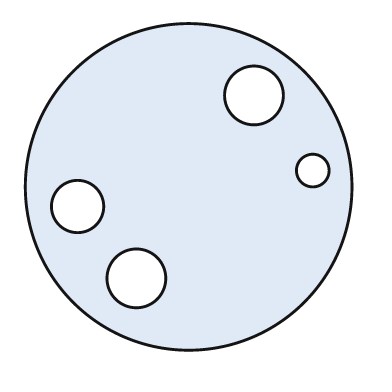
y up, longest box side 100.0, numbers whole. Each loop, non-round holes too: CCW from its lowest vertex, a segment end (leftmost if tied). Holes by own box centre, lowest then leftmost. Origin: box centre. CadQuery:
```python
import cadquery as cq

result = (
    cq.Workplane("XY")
    .moveTo(0.0, 0.0)
    .circle(50.0)
    .moveTo(-16.0, -28.0)
    .circle(9.0)
    .moveTo(-34.0, -6.0)
    .circle(8.0)
    .moveTo(38.0, 5.0)
    .circle(5.0)
    .moveTo(20.0, 28.0)
    .circle(9.0)
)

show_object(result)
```